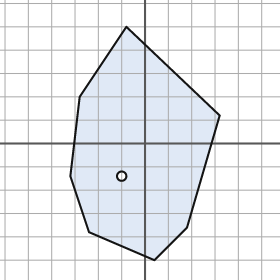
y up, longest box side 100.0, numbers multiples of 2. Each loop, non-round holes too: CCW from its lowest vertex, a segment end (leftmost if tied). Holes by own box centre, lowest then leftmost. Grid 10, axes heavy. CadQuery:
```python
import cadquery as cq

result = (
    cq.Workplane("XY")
    .moveTo(4.0, -50.0)
    .lineTo(18.0, -36.0)
    .lineTo(32.0, 12.0)
    .lineTo(-8.0, 50.0)
    .lineTo(-28.0, 20.0)
    .lineTo(-32.0, -14.0)
    .lineTo(-24.0, -38.0)
    .close()
    .moveTo(-10.0, -14.0)
    .circle(2.0)
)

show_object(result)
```